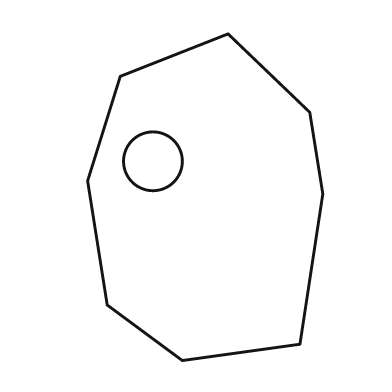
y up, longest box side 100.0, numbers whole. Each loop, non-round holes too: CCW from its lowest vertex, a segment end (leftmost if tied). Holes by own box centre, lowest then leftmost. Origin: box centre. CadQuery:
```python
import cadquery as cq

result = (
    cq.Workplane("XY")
    .moveTo(-7.0, -50.0)
    .lineTo(29.0, -45.0)
    .lineTo(36.0, 1.0)
    .lineTo(32.0, 26.0)
    .lineTo(7.0, 50.0)
    .lineTo(-26.0, 37.0)
    .lineTo(-36.0, 5.0)
    .lineTo(-30.0, -33.0)
    .close()
    .moveTo(-16.0, 11.0)
    .circle(9.0)
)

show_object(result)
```